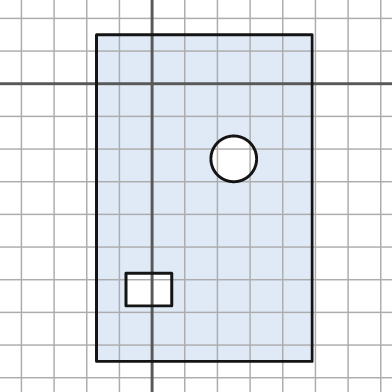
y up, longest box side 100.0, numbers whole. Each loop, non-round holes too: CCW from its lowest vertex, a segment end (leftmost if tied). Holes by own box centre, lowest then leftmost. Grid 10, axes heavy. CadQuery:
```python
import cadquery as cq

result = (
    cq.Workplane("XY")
    .moveTo(-17.0, -85.0)
    .lineTo(49.0, -85.0)
    .lineTo(49.0, 15.0)
    .lineTo(-17.0, 15.0)
    .close()
    .moveTo(-8.0, -68.0)
    .lineTo(6.0, -68.0)
    .lineTo(6.0, -58.0)
    .lineTo(-8.0, -58.0)
    .close()
    .moveTo(25.0, -23.0)
    .circle(7.0)
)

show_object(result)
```